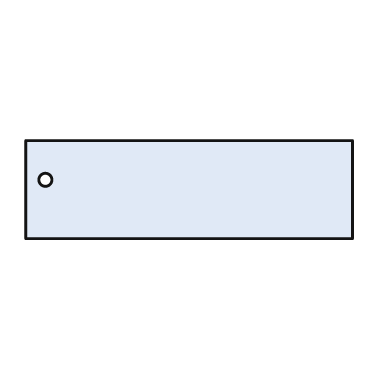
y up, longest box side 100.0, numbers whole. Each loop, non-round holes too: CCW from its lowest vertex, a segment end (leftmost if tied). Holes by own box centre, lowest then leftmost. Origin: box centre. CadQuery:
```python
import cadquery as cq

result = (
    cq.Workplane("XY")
    .moveTo(-50.0, -15.0)
    .lineTo(50.0, -15.0)
    .lineTo(50.0, 15.0)
    .lineTo(-50.0, 15.0)
    .close()
    .moveTo(-44.0, 3.0)
    .circle(2.0)
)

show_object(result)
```